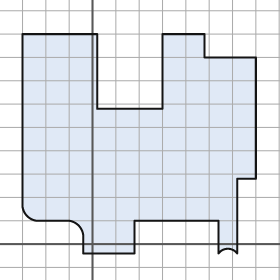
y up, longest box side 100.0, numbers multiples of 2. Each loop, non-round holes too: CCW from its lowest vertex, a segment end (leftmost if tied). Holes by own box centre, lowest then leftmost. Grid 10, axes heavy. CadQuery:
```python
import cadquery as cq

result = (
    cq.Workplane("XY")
    .moveTo(-4.0, -4.0)
    .lineTo(18.0, -4.0)
    .lineTo(18.0, 10.0)
    .lineTo(54.0, 10.0)
    .lineTo(54.0, -4.0)
    .threePointArc((58.0, -2.0), (62.0, -4.0))
    .lineTo(62.0, 28.0)
    .lineTo(70.0, 28.0)
    .lineTo(70.0, 80.0)
    .lineTo(48.0, 80.0)
    .lineTo(48.0, 90.0)
    .lineTo(30.0, 90.0)
    .lineTo(30.0, 58.0)
    .lineTo(2.0, 58.0)
    .lineTo(2.0, 90.0)
    .lineTo(-30.0, 90.0)
    .lineTo(-30.0, 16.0)
    .threePointArc((-28.0, 12.0), (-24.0, 10.0))
    .lineTo(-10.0, 10.0)
    .threePointArc((-6.0, 8.0), (-4.0, 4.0))
    .close()
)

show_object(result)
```